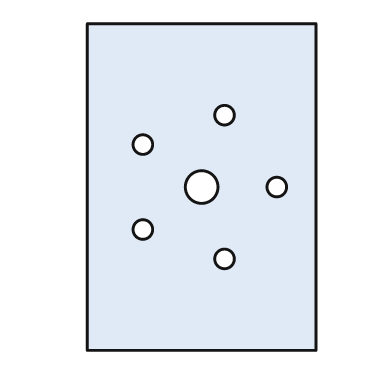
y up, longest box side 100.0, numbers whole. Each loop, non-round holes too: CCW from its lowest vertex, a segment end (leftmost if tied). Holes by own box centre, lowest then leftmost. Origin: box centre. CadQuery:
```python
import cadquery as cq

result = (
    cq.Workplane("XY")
    .moveTo(-35.0, -50.0)
    .lineTo(35.0, -50.0)
    .lineTo(35.0, 50.0)
    .lineTo(-35.0, 50.0)
    .close()
    .moveTo(7.0, -22.0)
    .circle(3.0)
    .moveTo(-18.0, -13.0)
    .circle(3.0)
    .moveTo(0.0, 0.0)
    .circle(5.0)
    .moveTo(23.0, 0.0)
    .circle(3.0)
    .moveTo(-18.0, 13.0)
    .circle(3.0)
    .moveTo(7.0, 22.0)
    .circle(3.0)
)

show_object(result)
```